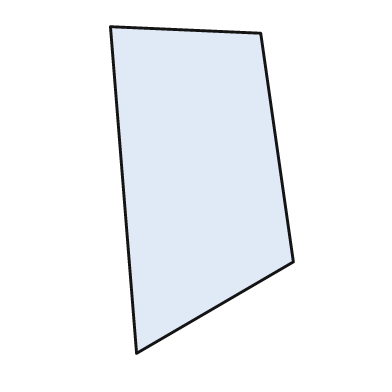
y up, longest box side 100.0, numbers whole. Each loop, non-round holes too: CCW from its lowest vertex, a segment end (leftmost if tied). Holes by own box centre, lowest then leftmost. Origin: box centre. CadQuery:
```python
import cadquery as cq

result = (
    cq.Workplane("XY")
    .moveTo(-20.0, -50.0)
    .lineTo(28.0, -22.0)
    .lineTo(18.0, 48.0)
    .lineTo(-28.0, 50.0)
    .close()
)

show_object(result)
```